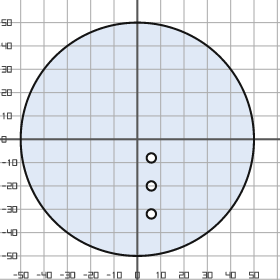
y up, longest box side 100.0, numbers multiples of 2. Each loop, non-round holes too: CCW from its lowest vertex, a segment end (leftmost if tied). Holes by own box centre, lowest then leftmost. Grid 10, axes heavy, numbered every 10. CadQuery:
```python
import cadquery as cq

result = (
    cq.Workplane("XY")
    .moveTo(0.0, 0.0)
    .circle(50.0)
    .moveTo(6.0, -32.0)
    .circle(2.0)
    .moveTo(6.0, -20.0)
    .circle(2.0)
    .moveTo(6.0, -8.0)
    .circle(2.0)
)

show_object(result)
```